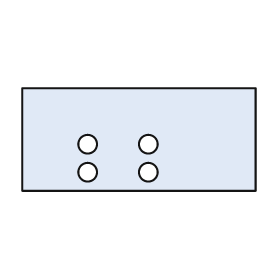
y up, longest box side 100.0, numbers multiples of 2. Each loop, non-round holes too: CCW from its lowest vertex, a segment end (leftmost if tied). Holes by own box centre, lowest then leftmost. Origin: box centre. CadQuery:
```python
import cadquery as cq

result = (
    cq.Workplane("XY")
    .moveTo(-50.0, -22.0)
    .lineTo(50.0, -22.0)
    .lineTo(50.0, 22.0)
    .lineTo(-50.0, 22.0)
    .close()
    .moveTo(-22.0, -14.0)
    .circle(4.0)
    .moveTo(4.0, -14.0)
    .circle(4.0)
    .moveTo(-22.0, -2.0)
    .circle(4.0)
    .moveTo(4.0, -2.0)
    .circle(4.0)
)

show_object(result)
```